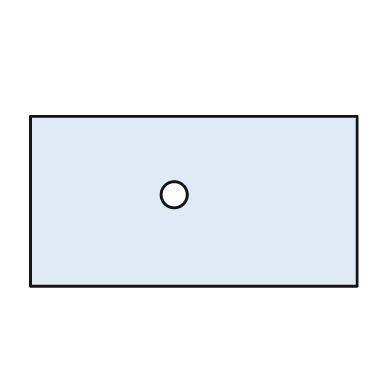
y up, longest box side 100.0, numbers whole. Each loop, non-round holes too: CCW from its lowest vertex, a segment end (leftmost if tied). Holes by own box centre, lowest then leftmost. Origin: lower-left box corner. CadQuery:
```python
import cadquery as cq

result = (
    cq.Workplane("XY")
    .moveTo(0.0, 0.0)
    .lineTo(100.0, 0.0)
    .lineTo(100.0, 52.0)
    .lineTo(0.0, 52.0)
    .close()
    .moveTo(44.0, 28.0)
    .circle(4.0)
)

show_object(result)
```